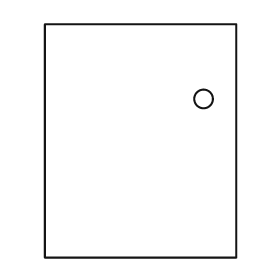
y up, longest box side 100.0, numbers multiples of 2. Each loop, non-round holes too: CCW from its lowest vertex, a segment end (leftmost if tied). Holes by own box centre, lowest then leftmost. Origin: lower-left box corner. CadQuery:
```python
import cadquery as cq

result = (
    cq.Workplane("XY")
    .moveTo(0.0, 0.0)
    .lineTo(82.0, 0.0)
    .lineTo(82.0, 100.0)
    .lineTo(0.0, 100.0)
    .close()
    .moveTo(68.0, 68.0)
    .circle(4.0)
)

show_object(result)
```